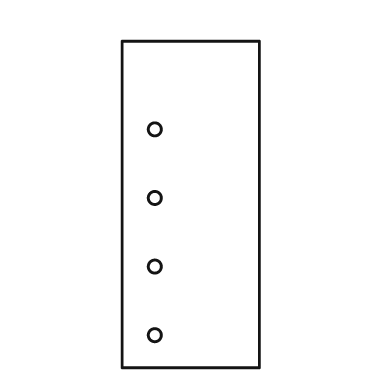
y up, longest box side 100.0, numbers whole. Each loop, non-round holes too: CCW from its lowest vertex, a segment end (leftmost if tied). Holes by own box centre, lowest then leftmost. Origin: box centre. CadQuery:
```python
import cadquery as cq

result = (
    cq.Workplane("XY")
    .moveTo(-21.0, -50.0)
    .lineTo(21.0, -50.0)
    .lineTo(21.0, 50.0)
    .lineTo(-21.0, 50.0)
    .close()
    .moveTo(-11.0, -40.0)
    .circle(2.0)
    .moveTo(-11.0, -19.0)
    .circle(2.0)
    .moveTo(-11.0, 2.0)
    .circle(2.0)
    .moveTo(-11.0, 23.0)
    .circle(2.0)
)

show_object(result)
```